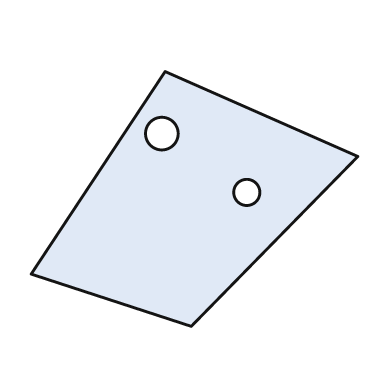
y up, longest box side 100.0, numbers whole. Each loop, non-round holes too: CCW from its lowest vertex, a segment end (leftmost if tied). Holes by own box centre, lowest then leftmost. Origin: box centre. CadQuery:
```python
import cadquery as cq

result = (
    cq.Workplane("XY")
    .moveTo(-1.0, -39.0)
    .lineTo(50.0, 13.0)
    .lineTo(-9.0, 39.0)
    .lineTo(-50.0, -23.0)
    .close()
    .moveTo(16.0, 2.0)
    .circle(4.0)
    .moveTo(-10.0, 20.0)
    .circle(5.0)
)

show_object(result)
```